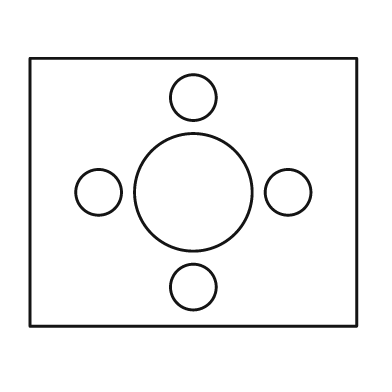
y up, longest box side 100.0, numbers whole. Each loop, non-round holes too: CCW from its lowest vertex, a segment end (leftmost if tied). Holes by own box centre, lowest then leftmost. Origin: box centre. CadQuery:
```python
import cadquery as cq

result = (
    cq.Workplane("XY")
    .moveTo(-50.0, -41.0)
    .lineTo(50.0, -41.0)
    .lineTo(50.0, 41.0)
    .lineTo(-50.0, 41.0)
    .close()
    .moveTo(0.0, -29.0)
    .circle(7.0)
    .moveTo(-29.0, 0.0)
    .circle(7.0)
    .moveTo(0.0, 0.0)
    .circle(18.0)
    .moveTo(29.0, 0.0)
    .circle(7.0)
    .moveTo(0.0, 29.0)
    .circle(7.0)
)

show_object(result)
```